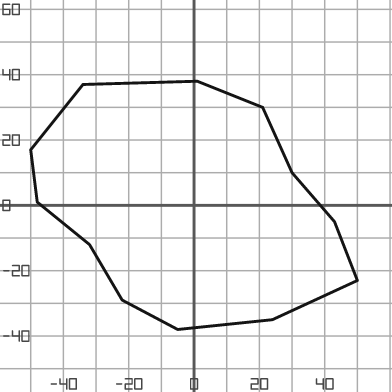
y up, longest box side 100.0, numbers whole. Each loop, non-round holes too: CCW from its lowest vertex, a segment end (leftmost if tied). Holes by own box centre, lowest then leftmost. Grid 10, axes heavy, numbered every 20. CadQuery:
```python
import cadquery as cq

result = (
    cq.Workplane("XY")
    .moveTo(-5.0, -38.0)
    .lineTo(24.0, -35.0)
    .lineTo(50.0, -23.0)
    .lineTo(43.0, -5.0)
    .lineTo(30.0, 10.0)
    .lineTo(21.0, 30.0)
    .lineTo(1.0, 38.0)
    .lineTo(-34.0, 37.0)
    .lineTo(-50.0, 17.0)
    .lineTo(-48.0, 1.0)
    .lineTo(-32.0, -12.0)
    .lineTo(-22.0, -29.0)
    .close()
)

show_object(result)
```